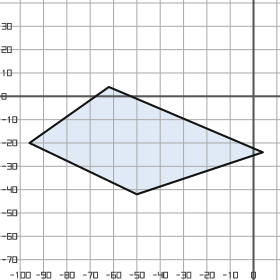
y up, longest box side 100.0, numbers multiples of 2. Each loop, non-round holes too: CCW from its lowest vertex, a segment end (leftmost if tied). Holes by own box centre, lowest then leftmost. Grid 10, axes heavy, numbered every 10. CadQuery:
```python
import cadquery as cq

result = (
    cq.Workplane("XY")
    .moveTo(-50.0, -42.0)
    .lineTo(4.0, -24.0)
    .lineTo(-62.0, 4.0)
    .lineTo(-96.0, -20.0)
    .close()
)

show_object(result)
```